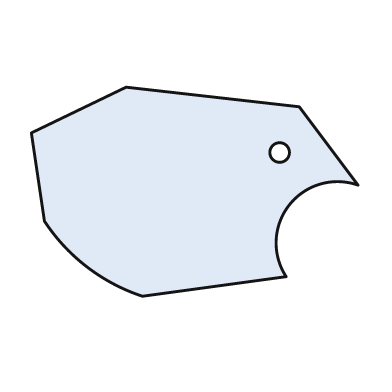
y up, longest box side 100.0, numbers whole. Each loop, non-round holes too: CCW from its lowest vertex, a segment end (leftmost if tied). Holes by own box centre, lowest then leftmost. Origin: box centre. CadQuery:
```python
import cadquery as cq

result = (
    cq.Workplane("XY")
    .moveTo(-16.0, -32.0)
    .lineTo(28.0, -26.0)
    .threePointArc((29.0, -4.0), (50.0, 2.0))
    .lineTo(32.0, 26.0)
    .lineTo(-21.0, 32.0)
    .lineTo(-50.0, 18.0)
    .lineTo(-46.0, -9.0)
    .threePointArc((-33.0, -23.0), (-16.0, -32.0))
    .close()
    .moveTo(26.0, 12.0)
    .circle(3.0)
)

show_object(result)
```